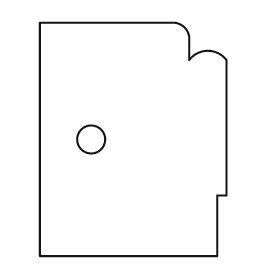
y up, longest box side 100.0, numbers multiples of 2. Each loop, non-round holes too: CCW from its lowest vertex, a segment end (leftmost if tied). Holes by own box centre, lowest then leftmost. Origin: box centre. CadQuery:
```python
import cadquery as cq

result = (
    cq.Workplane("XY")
    .moveTo(-40.0, -50.0)
    .lineTo(36.0, -50.0)
    .lineTo(36.0, -24.0)
    .lineTo(40.0, -24.0)
    .lineTo(40.0, 34.0)
    .threePointArc((32.0, 38.0), (24.0, 34.0))
    .lineTo(24.0, 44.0)
    .threePointArc((22.0, 48.0), (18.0, 50.0))
    .lineTo(-40.0, 50.0)
    .close()
    .moveTo(-18.0, 0.0)
    .circle(6.0)
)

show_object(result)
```